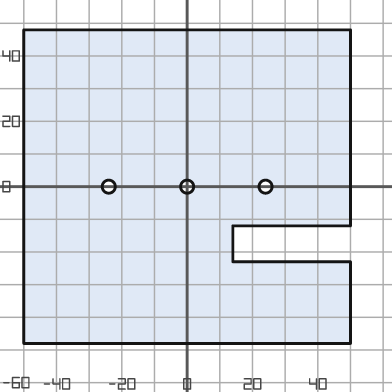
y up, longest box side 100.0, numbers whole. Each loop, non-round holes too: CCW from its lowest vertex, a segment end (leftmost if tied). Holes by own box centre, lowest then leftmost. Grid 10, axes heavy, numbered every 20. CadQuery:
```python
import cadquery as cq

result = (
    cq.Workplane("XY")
    .moveTo(-50.0, -48.0)
    .lineTo(50.0, -48.0)
    .lineTo(50.0, -23.0)
    .lineTo(14.0, -23.0)
    .lineTo(14.0, -12.0)
    .lineTo(50.0, -12.0)
    .lineTo(50.0, 48.0)
    .lineTo(-50.0, 48.0)
    .close()
    .moveTo(-24.0, 0.0)
    .circle(2.0)
    .moveTo(0.0, 0.0)
    .circle(2.0)
    .moveTo(24.0, 0.0)
    .circle(2.0)
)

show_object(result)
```